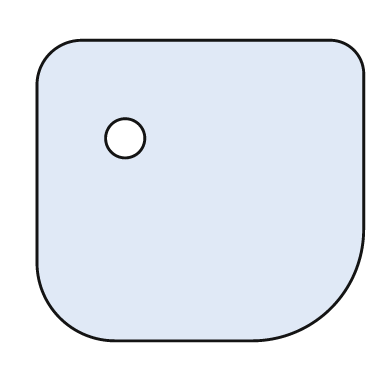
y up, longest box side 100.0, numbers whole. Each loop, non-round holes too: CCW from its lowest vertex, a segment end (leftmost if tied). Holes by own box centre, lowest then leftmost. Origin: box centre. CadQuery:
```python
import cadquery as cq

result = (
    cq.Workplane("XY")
    .moveTo(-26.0, -46.0)
    .lineTo(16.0, -46.0)
    .threePointArc((40.0, -36.0), (50.0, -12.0))
    .lineTo(50.0, 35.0)
    .threePointArc((47.0, 43.0), (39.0, 46.0))
    .lineTo(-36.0, 46.0)
    .threePointArc((-46.0, 42.0), (-50.0, 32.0))
    .lineTo(-50.0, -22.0)
    .threePointArc((-43.0, -39.0), (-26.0, -46.0))
    .close()
    .moveTo(-23.0, 16.0)
    .circle(6.0)
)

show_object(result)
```